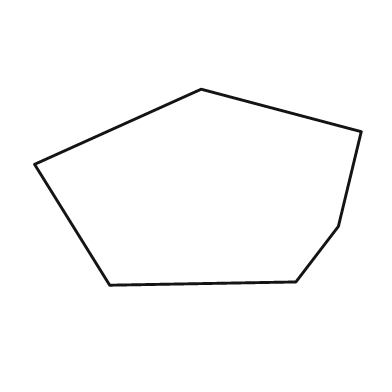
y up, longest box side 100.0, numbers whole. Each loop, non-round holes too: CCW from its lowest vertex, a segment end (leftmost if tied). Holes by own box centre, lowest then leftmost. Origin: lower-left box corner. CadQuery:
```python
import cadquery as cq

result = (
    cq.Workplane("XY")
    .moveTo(23.0, 0.0)
    .lineTo(80.0, 1.0)
    .lineTo(93.0, 18.0)
    .lineTo(100.0, 47.0)
    .lineTo(51.0, 60.0)
    .lineTo(0.0, 37.0)
    .close()
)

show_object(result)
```